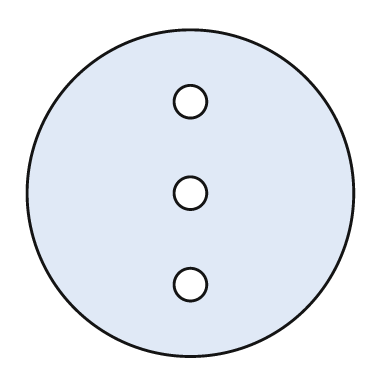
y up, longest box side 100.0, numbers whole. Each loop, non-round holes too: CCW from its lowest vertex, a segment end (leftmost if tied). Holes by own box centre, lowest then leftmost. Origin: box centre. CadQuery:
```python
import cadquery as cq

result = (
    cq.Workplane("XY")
    .moveTo(0.0, 0.0)
    .circle(50.0)
    .moveTo(0.0, -28.0)
    .circle(5.0)
    .moveTo(0.0, 0.0)
    .circle(5.0)
    .moveTo(0.0, 28.0)
    .circle(5.0)
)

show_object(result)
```